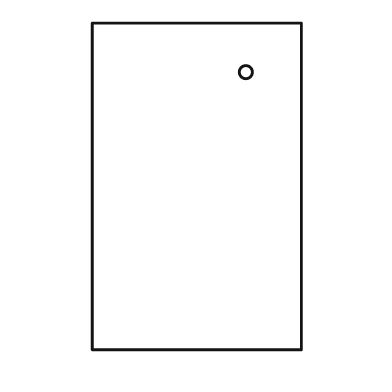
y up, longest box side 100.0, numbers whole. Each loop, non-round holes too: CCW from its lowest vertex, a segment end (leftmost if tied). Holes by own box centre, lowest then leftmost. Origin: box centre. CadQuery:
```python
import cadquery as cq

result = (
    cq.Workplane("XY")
    .moveTo(-32.0, -50.0)
    .lineTo(32.0, -50.0)
    .lineTo(32.0, 50.0)
    .lineTo(-32.0, 50.0)
    .close()
    .moveTo(15.0, 35.0)
    .circle(2.0)
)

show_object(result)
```